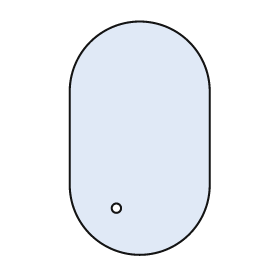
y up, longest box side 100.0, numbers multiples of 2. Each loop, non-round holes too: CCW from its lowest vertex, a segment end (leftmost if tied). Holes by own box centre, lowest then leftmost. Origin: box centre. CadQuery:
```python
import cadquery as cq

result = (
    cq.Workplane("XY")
    .moveTo(-30.0, -20.0)
    .threePointArc((0.0, -50.0), (30.0, -20.0))
    .lineTo(30.0, 20.0)
    .threePointArc((0.0, 50.0), (-30.0, 20.0))
    .close()
    .moveTo(-10.0, -30.0)
    .circle(2.0)
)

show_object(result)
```